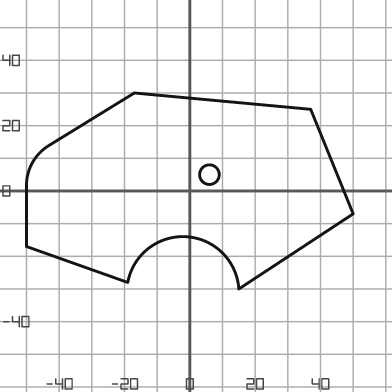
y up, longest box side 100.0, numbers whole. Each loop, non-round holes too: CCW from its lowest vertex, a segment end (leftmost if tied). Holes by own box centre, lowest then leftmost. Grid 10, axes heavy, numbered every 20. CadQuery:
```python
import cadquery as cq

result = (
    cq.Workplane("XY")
    .moveTo(15.0, -30.0)
    .lineTo(50.0, -7.0)
    .lineTo(37.0, 25.0)
    .lineTo(-17.0, 30.0)
    .lineTo(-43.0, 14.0)
    .threePointArc((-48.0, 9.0), (-50.0, 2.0))
    .lineTo(-50.0, -17.0)
    .lineTo(-19.0, -28.0)
    .threePointArc((-1.0, -14.0), (15.0, -30.0))
    .close()
    .moveTo(6.0, 5.0)
    .circle(3.0)
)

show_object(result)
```